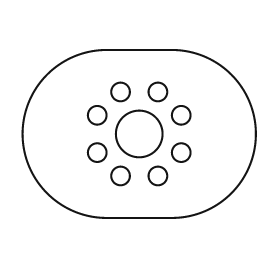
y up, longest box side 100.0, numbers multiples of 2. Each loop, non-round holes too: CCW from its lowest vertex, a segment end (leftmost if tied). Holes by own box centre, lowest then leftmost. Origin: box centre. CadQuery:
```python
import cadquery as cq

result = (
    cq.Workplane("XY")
    .moveTo(-14.0, -36.0)
    .lineTo(14.0, -36.0)
    .threePointArc((50.0, 0.0), (14.0, 36.0))
    .lineTo(-14.0, 36.0)
    .threePointArc((-50.0, 0.0), (-14.0, -36.0))
    .close()
    .moveTo(-8.0, -18.0)
    .circle(4.0)
    .moveTo(8.0, -18.0)
    .circle(4.0)
    .moveTo(-18.0, -8.0)
    .circle(4.0)
    .moveTo(18.0, -8.0)
    .circle(4.0)
    .moveTo(0.0, 0.0)
    .circle(10.0)
    .moveTo(-18.0, 8.0)
    .circle(4.0)
    .moveTo(18.0, 8.0)
    .circle(4.0)
    .moveTo(-8.0, 18.0)
    .circle(4.0)
    .moveTo(8.0, 18.0)
    .circle(4.0)
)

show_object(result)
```